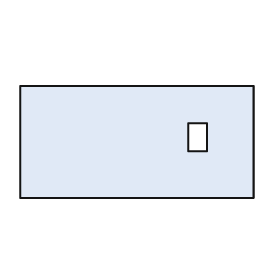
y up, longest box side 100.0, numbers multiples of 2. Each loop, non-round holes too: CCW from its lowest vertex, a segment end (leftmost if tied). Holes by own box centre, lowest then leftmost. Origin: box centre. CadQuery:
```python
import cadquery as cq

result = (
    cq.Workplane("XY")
    .moveTo(-50.0, -24.0)
    .lineTo(50.0, -24.0)
    .lineTo(50.0, 24.0)
    .lineTo(-50.0, 24.0)
    .close()
    .moveTo(22.0, -4.0)
    .lineTo(30.0, -4.0)
    .lineTo(30.0, 8.0)
    .lineTo(22.0, 8.0)
    .close()
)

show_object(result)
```